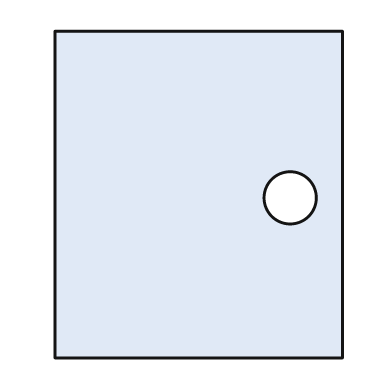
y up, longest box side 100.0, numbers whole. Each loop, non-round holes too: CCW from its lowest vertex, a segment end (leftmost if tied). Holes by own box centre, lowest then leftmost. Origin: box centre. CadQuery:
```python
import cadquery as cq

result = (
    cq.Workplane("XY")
    .moveTo(-44.0, -50.0)
    .lineTo(44.0, -50.0)
    .lineTo(44.0, 50.0)
    .lineTo(-44.0, 50.0)
    .close()
    .moveTo(28.0, -1.0)
    .circle(8.0)
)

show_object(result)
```